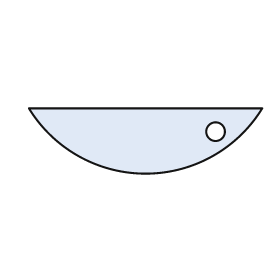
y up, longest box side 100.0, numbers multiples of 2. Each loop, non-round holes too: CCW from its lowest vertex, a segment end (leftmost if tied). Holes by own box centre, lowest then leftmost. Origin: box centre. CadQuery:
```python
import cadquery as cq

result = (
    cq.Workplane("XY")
    .moveTo(-50.0, 14.0)
    .threePointArc((0.0, -14.0), (50.0, 14.0))
    .close()
    .moveTo(30.0, 4.0)
    .circle(4.0)
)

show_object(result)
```